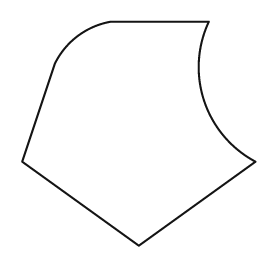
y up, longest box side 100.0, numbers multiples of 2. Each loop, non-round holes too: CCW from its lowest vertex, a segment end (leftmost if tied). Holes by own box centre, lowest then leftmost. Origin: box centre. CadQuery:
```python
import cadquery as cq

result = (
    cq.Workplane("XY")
    .moveTo(0.0, -48.0)
    .lineTo(50.0, -12.0)
    .threePointArc((28.0, 14.0), (30.0, 48.0))
    .lineTo(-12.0, 48.0)
    .threePointArc((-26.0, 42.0), (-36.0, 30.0))
    .lineTo(-50.0, -12.0)
    .close()
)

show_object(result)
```